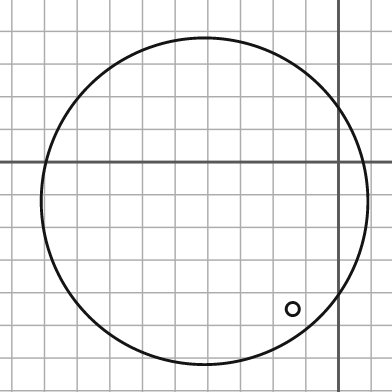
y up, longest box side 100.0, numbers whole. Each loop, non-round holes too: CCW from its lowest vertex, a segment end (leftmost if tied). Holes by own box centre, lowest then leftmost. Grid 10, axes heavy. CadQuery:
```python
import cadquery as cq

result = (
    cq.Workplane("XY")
    .moveTo(-41.0, -12.0)
    .circle(50.0)
    .moveTo(-14.0, -45.0)
    .circle(2.0)
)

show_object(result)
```